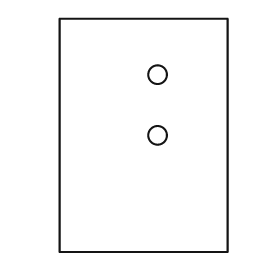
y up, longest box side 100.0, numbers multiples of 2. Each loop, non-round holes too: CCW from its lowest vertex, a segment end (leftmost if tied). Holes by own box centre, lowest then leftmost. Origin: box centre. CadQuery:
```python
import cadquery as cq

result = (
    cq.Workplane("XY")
    .moveTo(-36.0, -50.0)
    .lineTo(36.0, -50.0)
    .lineTo(36.0, 50.0)
    .lineTo(-36.0, 50.0)
    .close()
    .moveTo(6.0, 0.0)
    .circle(4.0)
    .moveTo(6.0, 26.0)
    .circle(4.0)
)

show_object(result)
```